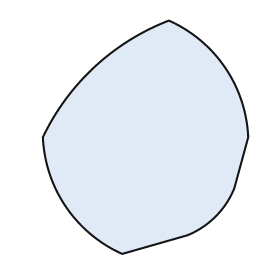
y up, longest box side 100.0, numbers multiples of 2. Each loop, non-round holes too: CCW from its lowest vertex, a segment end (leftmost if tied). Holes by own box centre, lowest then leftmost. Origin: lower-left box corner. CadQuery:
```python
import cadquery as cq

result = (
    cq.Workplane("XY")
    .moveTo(34.0, 0.0)
    .lineTo(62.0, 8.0)
    .threePointArc((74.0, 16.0), (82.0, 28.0))
    .lineTo(88.0, 50.0)
    .threePointArc((78.0, 80.0), (54.0, 100.0))
    .threePointArc((22.0, 80.0), (0.0, 50.0))
    .threePointArc((10.0, 20.0), (34.0, 0.0))
    .close()
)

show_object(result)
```